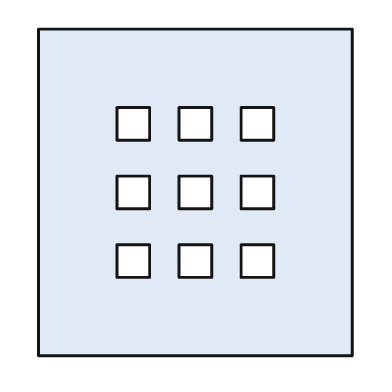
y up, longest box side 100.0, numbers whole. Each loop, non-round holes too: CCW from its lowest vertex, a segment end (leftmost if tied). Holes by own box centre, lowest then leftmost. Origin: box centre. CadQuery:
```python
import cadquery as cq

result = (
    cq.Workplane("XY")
    .moveTo(-48.0, -50.0)
    .lineTo(48.0, -50.0)
    .lineTo(48.0, 50.0)
    .lineTo(-48.0, 50.0)
    .close()
    .moveTo(-24.0, -26.0)
    .lineTo(-14.0, -26.0)
    .lineTo(-14.0, -16.0)
    .lineTo(-24.0, -16.0)
    .close()
    .moveTo(-5.0, -26.0)
    .lineTo(5.0, -26.0)
    .lineTo(5.0, -16.0)
    .lineTo(-5.0, -16.0)
    .close()
    .moveTo(14.0, -26.0)
    .lineTo(24.0, -26.0)
    .lineTo(24.0, -16.0)
    .lineTo(14.0, -16.0)
    .close()
    .moveTo(-24.0, -5.0)
    .lineTo(-14.0, -5.0)
    .lineTo(-14.0, 5.0)
    .lineTo(-24.0, 5.0)
    .close()
    .moveTo(-5.0, -5.0)
    .lineTo(5.0, -5.0)
    .lineTo(5.0, 5.0)
    .lineTo(-5.0, 5.0)
    .close()
    .moveTo(14.0, -5.0)
    .lineTo(24.0, -5.0)
    .lineTo(24.0, 5.0)
    .lineTo(14.0, 5.0)
    .close()
    .moveTo(-24.0, 16.0)
    .lineTo(-14.0, 16.0)
    .lineTo(-14.0, 26.0)
    .lineTo(-24.0, 26.0)
    .close()
    .moveTo(-5.0, 16.0)
    .lineTo(5.0, 16.0)
    .lineTo(5.0, 26.0)
    .lineTo(-5.0, 26.0)
    .close()
    .moveTo(14.0, 16.0)
    .lineTo(24.0, 16.0)
    .lineTo(24.0, 26.0)
    .lineTo(14.0, 26.0)
    .close()
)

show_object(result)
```